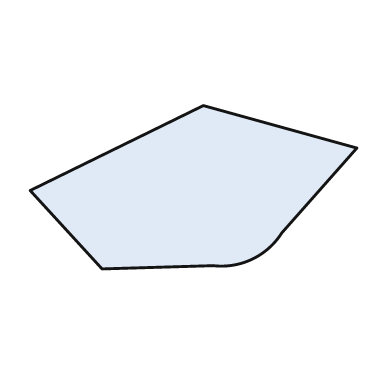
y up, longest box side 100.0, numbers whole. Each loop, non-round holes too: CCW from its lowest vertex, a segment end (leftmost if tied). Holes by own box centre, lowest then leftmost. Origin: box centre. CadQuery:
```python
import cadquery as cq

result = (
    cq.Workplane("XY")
    .moveTo(-28.0, -25.0)
    .lineTo(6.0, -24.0)
    .threePointArc((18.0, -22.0), (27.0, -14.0))
    .lineTo(50.0, 12.0)
    .lineTo(3.0, 25.0)
    .lineTo(-50.0, -1.0)
    .close()
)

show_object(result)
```